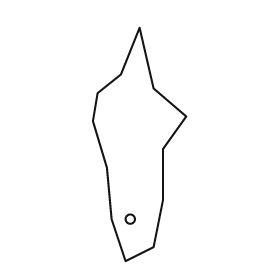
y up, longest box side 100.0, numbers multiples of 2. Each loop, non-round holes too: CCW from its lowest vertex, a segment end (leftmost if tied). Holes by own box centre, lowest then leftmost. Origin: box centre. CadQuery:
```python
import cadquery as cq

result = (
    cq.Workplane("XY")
    .moveTo(-6.0, -50.0)
    .lineTo(6.0, -44.0)
    .lineTo(10.0, -24.0)
    .lineTo(10.0, -2.0)
    .lineTo(20.0, 12.0)
    .lineTo(6.0, 24.0)
    .lineTo(0.0, 50.0)
    .lineTo(-8.0, 30.0)
    .lineTo(-18.0, 22.0)
    .lineTo(-20.0, 10.0)
    .lineTo(-14.0, -10.0)
    .lineTo(-12.0, -32.0)
    .close()
    .moveTo(-4.0, -32.0)
    .circle(2.0)
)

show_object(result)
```